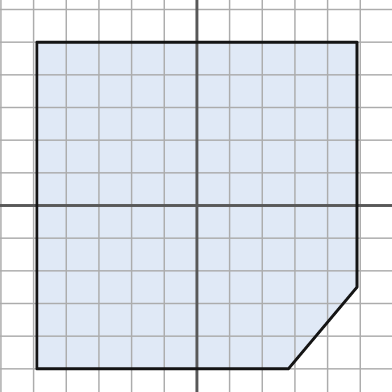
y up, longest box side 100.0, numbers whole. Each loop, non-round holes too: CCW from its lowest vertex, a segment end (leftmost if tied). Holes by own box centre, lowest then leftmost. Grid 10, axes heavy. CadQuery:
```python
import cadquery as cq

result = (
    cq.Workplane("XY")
    .moveTo(-49.0, -50.0)
    .lineTo(28.0, -50.0)
    .lineTo(49.0, -25.0)
    .lineTo(49.0, 50.0)
    .lineTo(-49.0, 50.0)
    .close()
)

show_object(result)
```